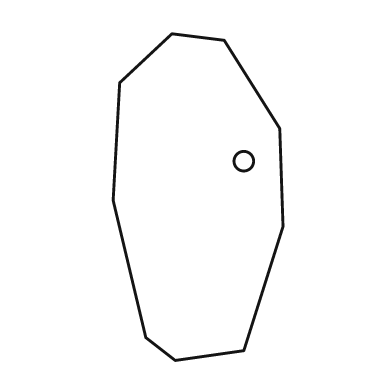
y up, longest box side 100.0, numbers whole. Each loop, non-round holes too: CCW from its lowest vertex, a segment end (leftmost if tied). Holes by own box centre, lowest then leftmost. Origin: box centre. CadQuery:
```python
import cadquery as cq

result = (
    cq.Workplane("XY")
    .moveTo(-7.0, -50.0)
    .lineTo(14.0, -47.0)
    .lineTo(26.0, -9.0)
    .lineTo(25.0, 21.0)
    .lineTo(8.0, 48.0)
    .lineTo(-8.0, 50.0)
    .lineTo(-24.0, 35.0)
    .lineTo(-26.0, -1.0)
    .lineTo(-16.0, -43.0)
    .close()
    .moveTo(14.0, 11.0)
    .circle(3.0)
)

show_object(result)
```